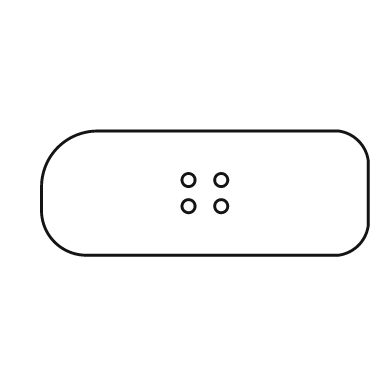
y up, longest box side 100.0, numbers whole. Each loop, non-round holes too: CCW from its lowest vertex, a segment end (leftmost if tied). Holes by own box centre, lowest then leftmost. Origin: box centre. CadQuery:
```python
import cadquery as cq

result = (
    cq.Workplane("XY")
    .moveTo(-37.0, -19.0)
    .lineTo(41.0, -19.0)
    .threePointArc((47.0, -16.0), (50.0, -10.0))
    .lineTo(50.0, 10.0)
    .threePointArc((47.0, 16.0), (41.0, 19.0))
    .lineTo(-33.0, 19.0)
    .threePointArc((-45.0, 14.0), (-50.0, 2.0))
    .lineTo(-50.0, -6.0)
    .threePointArc((-46.0, -15.0), (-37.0, -19.0))
    .close()
    .moveTo(-5.0, -4.0)
    .circle(2.0)
    .moveTo(5.0, -4.0)
    .circle(2.0)
    .moveTo(-5.0, 4.0)
    .circle(2.0)
    .moveTo(5.0, 4.0)
    .circle(2.0)
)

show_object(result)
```